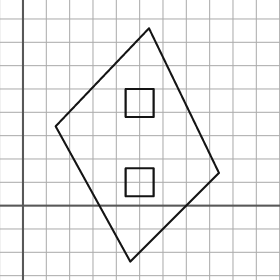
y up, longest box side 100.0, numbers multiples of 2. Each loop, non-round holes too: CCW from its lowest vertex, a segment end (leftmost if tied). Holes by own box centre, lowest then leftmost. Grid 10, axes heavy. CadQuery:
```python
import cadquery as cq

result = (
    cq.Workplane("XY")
    .moveTo(46.0, -24.0)
    .lineTo(84.0, 14.0)
    .lineTo(54.0, 76.0)
    .lineTo(14.0, 34.0)
    .close()
    .moveTo(44.0, 4.0)
    .lineTo(56.0, 4.0)
    .lineTo(56.0, 16.0)
    .lineTo(44.0, 16.0)
    .close()
    .moveTo(44.0, 38.0)
    .lineTo(56.0, 38.0)
    .lineTo(56.0, 50.0)
    .lineTo(44.0, 50.0)
    .close()
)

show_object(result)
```